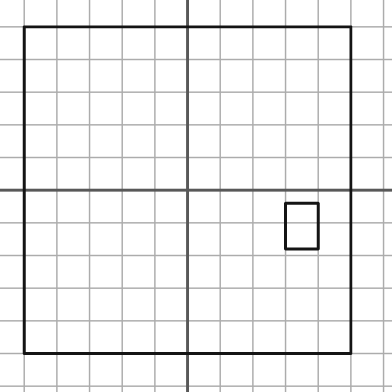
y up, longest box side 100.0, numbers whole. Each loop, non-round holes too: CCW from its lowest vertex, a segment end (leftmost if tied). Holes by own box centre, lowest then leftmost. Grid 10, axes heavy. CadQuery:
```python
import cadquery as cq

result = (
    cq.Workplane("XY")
    .moveTo(-50.0, -50.0)
    .lineTo(50.0, -50.0)
    .lineTo(50.0, 50.0)
    .lineTo(-50.0, 50.0)
    .close()
    .moveTo(30.0, -18.0)
    .lineTo(40.0, -18.0)
    .lineTo(40.0, -4.0)
    .lineTo(30.0, -4.0)
    .close()
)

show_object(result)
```